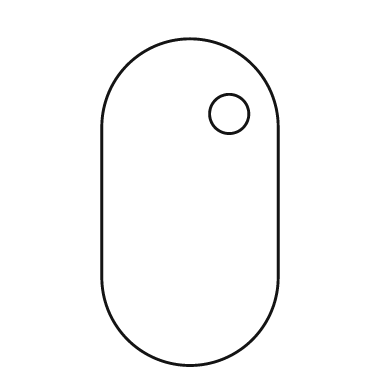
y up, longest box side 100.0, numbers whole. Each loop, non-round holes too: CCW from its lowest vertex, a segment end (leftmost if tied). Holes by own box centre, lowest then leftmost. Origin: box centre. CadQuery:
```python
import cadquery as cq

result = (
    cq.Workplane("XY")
    .moveTo(-27.0, -23.0)
    .threePointArc((0.0, -50.0), (27.0, -23.0))
    .lineTo(27.0, 23.0)
    .threePointArc((0.0, 50.0), (-27.0, 23.0))
    .close()
    .moveTo(12.0, 27.0)
    .circle(6.0)
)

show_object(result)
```